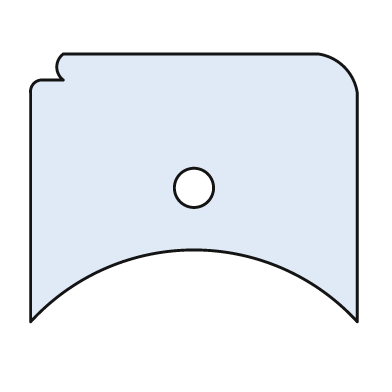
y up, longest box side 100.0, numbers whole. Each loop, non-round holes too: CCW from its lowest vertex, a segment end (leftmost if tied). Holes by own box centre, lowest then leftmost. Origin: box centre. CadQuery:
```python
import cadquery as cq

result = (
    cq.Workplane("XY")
    .moveTo(-50.0, -41.0)
    .threePointArc((0.0, -19.0), (50.0, -41.0))
    .lineTo(50.0, 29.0)
    .threePointArc((46.0, 37.0), (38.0, 41.0))
    .lineTo(-40.0, 41.0)
    .threePointArc((-42.0, 37.0), (-40.0, 33.0))
    .lineTo(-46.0, 33.0)
    .threePointArc((-49.0, 32.0), (-50.0, 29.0))
    .close()
    .moveTo(0.0, 0.0)
    .circle(6.0)
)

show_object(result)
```